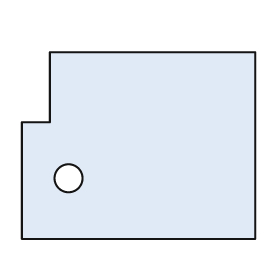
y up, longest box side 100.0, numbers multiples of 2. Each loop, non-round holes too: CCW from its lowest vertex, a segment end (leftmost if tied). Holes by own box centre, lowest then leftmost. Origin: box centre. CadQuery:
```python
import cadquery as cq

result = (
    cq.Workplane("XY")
    .moveTo(-50.0, -40.0)
    .lineTo(50.0, -40.0)
    .lineTo(50.0, 40.0)
    .lineTo(-38.0, 40.0)
    .lineTo(-38.0, 10.0)
    .lineTo(-50.0, 10.0)
    .close()
    .moveTo(-30.0, -14.0)
    .circle(6.0)
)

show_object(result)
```